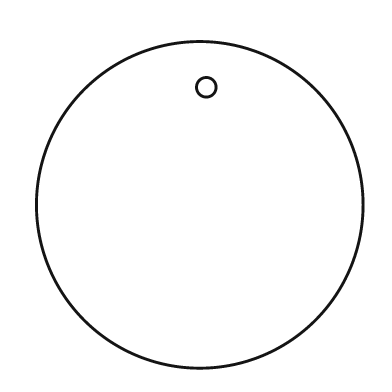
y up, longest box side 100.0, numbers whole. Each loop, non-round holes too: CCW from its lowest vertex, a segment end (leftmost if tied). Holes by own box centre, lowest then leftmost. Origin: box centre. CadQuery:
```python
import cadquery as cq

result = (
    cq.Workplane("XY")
    .moveTo(0.0, 0.0)
    .circle(50.0)
    .moveTo(2.0, 36.0)
    .circle(3.0)
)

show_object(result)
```